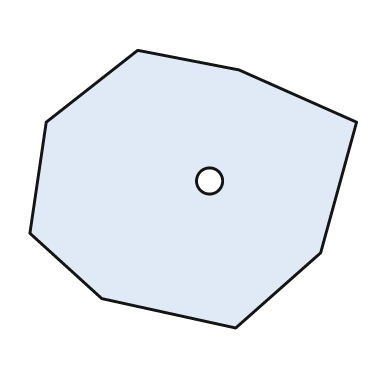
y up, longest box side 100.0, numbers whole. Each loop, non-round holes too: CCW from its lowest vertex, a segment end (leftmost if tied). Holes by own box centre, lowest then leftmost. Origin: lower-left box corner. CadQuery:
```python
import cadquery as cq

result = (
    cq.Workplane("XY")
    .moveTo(63.0, 0.0)
    .lineTo(89.0, 23.0)
    .lineTo(100.0, 63.0)
    .lineTo(64.0, 79.0)
    .lineTo(33.0, 85.0)
    .lineTo(5.0, 63.0)
    .lineTo(0.0, 29.0)
    .lineTo(22.0, 9.0)
    .close()
    .moveTo(55.0, 45.0)
    .circle(4.0)
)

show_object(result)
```